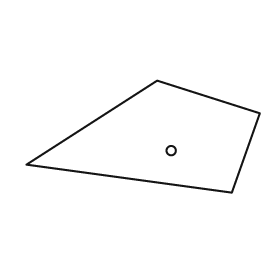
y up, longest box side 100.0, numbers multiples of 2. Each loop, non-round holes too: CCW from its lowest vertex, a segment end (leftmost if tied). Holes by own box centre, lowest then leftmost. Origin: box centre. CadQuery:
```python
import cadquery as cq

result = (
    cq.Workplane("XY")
    .moveTo(38.0, -24.0)
    .lineTo(50.0, 10.0)
    .lineTo(6.0, 24.0)
    .lineTo(-50.0, -12.0)
    .close()
    .moveTo(12.0, -6.0)
    .circle(2.0)
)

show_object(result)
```